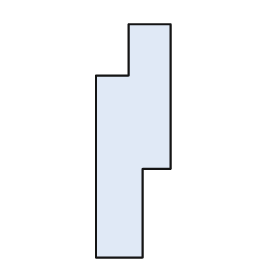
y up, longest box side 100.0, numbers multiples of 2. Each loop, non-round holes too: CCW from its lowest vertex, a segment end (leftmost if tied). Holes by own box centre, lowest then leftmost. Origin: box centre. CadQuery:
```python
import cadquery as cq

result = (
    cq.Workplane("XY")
    .moveTo(-16.0, -50.0)
    .lineTo(4.0, -50.0)
    .lineTo(4.0, -12.0)
    .lineTo(16.0, -12.0)
    .lineTo(16.0, 50.0)
    .lineTo(-2.0, 50.0)
    .lineTo(-2.0, 28.0)
    .lineTo(-16.0, 28.0)
    .close()
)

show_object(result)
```